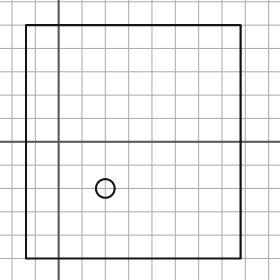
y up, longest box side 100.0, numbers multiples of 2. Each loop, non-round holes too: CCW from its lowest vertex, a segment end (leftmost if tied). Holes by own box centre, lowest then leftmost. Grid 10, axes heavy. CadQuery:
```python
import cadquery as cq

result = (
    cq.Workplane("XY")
    .moveTo(-14.0, -50.0)
    .lineTo(78.0, -50.0)
    .lineTo(78.0, 50.0)
    .lineTo(-14.0, 50.0)
    .close()
    .moveTo(20.0, -20.0)
    .circle(4.0)
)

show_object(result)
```